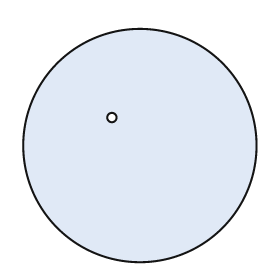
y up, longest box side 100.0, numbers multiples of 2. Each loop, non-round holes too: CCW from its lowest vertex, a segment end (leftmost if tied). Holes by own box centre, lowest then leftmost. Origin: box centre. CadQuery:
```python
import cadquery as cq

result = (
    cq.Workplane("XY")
    .moveTo(0.0, 0.0)
    .circle(50.0)
    .moveTo(-12.0, 12.0)
    .circle(2.0)
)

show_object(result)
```